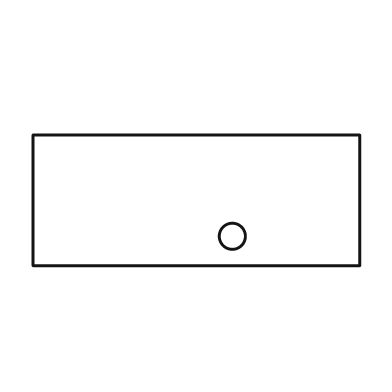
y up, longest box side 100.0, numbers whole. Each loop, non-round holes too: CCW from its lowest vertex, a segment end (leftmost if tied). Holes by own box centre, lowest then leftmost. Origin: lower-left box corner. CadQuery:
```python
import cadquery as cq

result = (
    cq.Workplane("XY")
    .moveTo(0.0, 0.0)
    .lineTo(100.0, 0.0)
    .lineTo(100.0, 40.0)
    .lineTo(0.0, 40.0)
    .close()
    .moveTo(61.0, 9.0)
    .circle(4.0)
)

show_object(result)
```